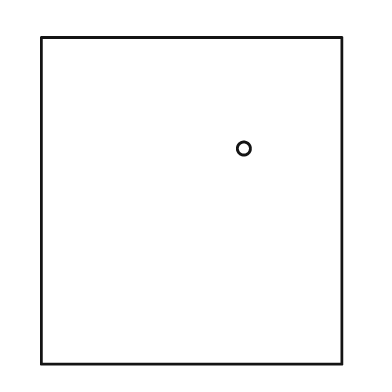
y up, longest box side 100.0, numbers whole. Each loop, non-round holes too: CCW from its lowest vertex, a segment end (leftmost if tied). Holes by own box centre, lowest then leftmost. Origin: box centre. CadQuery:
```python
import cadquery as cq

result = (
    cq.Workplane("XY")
    .moveTo(-46.0, -50.0)
    .lineTo(46.0, -50.0)
    .lineTo(46.0, 50.0)
    .lineTo(-46.0, 50.0)
    .close()
    .moveTo(16.0, 16.0)
    .circle(2.0)
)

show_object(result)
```